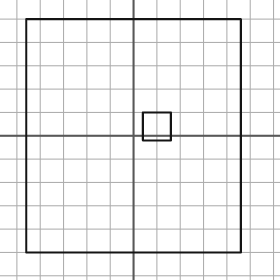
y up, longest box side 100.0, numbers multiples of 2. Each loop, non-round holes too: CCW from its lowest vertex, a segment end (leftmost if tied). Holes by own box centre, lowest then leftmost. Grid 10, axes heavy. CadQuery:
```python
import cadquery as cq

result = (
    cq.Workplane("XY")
    .moveTo(-46.0, -50.0)
    .lineTo(46.0, -50.0)
    .lineTo(46.0, 50.0)
    .lineTo(-46.0, 50.0)
    .close()
    .moveTo(4.0, -2.0)
    .lineTo(16.0, -2.0)
    .lineTo(16.0, 10.0)
    .lineTo(4.0, 10.0)
    .close()
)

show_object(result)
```